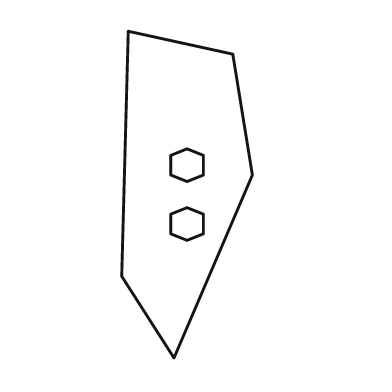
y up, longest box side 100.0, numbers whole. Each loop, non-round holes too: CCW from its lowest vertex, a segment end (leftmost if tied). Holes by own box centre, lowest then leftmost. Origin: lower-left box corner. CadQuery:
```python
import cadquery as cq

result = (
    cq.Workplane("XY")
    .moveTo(16.0, 0.0)
    .lineTo(40.0, 56.0)
    .lineTo(34.0, 93.0)
    .lineTo(2.0, 100.0)
    .lineTo(0.0, 25.0)
    .close()
    .moveTo(20.0, 36.0)
    .lineTo(25.0, 38.0)
    .lineTo(25.0, 44.0)
    .lineTo(20.0, 46.0)
    .lineTo(15.0, 44.0)
    .lineTo(15.0, 38.0)
    .close()
    .moveTo(20.0, 54.0)
    .lineTo(25.0, 56.0)
    .lineTo(25.0, 62.0)
    .lineTo(20.0, 64.0)
    .lineTo(15.0, 62.0)
    .lineTo(15.0, 56.0)
    .close()
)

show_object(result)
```